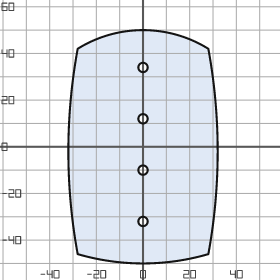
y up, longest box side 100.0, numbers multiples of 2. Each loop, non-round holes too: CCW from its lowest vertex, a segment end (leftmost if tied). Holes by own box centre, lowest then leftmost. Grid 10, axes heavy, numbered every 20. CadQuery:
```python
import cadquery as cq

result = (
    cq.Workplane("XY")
    .moveTo(-28.0, -46.0)
    .threePointArc((0.0, -50.0), (28.0, -46.0))
    .threePointArc((32.0, -2.0), (28.0, 42.0))
    .threePointArc((0.0, 50.0), (-28.0, 42.0))
    .threePointArc((-32.0, -2.0), (-28.0, -46.0))
    .close()
    .moveTo(0.0, -32.0)
    .circle(2.0)
    .moveTo(0.0, -10.0)
    .circle(2.0)
    .moveTo(0.0, 12.0)
    .circle(2.0)
    .moveTo(0.0, 34.0)
    .circle(2.0)
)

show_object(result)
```